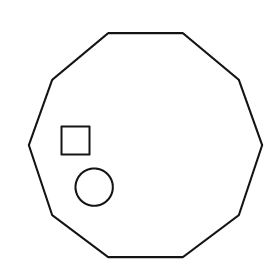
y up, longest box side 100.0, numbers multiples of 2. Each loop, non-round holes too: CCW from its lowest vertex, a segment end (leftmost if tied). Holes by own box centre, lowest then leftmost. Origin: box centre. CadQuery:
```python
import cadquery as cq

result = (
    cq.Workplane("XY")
    .moveTo(-16.0, -48.0)
    .lineTo(16.0, -48.0)
    .lineTo(40.0, -30.0)
    .lineTo(50.0, 0.0)
    .lineTo(40.0, 28.0)
    .lineTo(16.0, 48.0)
    .lineTo(-16.0, 48.0)
    .lineTo(-40.0, 28.0)
    .lineTo(-50.0, 0.0)
    .lineTo(-40.0, -30.0)
    .close()
    .moveTo(-22.0, -18.0)
    .circle(8.0)
    .moveTo(-36.0, -4.0)
    .lineTo(-24.0, -4.0)
    .lineTo(-24.0, 8.0)
    .lineTo(-36.0, 8.0)
    .close()
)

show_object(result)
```